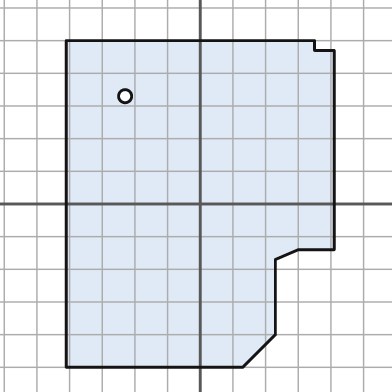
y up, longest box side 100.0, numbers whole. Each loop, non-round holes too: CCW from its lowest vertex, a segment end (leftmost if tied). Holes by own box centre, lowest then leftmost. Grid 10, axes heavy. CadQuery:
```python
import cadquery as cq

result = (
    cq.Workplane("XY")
    .moveTo(-41.0, -50.0)
    .lineTo(13.0, -50.0)
    .lineTo(23.0, -40.0)
    .lineTo(23.0, -17.0)
    .lineTo(30.0, -14.0)
    .lineTo(41.0, -14.0)
    .lineTo(41.0, 47.0)
    .lineTo(35.0, 47.0)
    .lineTo(35.0, 50.0)
    .lineTo(-41.0, 50.0)
    .close()
    .moveTo(-23.0, 33.0)
    .circle(2.0)
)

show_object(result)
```